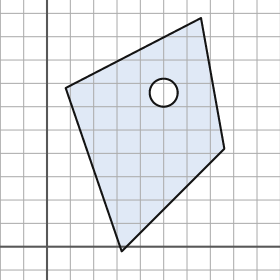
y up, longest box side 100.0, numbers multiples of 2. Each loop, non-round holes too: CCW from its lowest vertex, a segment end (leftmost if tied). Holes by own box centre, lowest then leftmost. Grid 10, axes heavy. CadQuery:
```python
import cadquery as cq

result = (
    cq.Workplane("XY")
    .moveTo(32.0, -2.0)
    .lineTo(76.0, 42.0)
    .lineTo(66.0, 98.0)
    .lineTo(8.0, 68.0)
    .close()
    .moveTo(50.0, 66.0)
    .circle(6.0)
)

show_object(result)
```